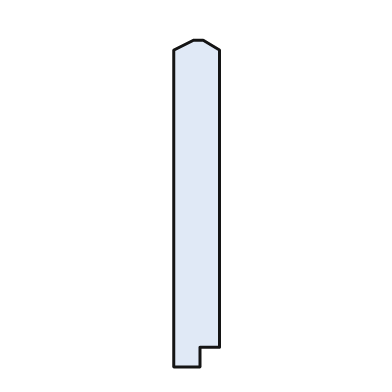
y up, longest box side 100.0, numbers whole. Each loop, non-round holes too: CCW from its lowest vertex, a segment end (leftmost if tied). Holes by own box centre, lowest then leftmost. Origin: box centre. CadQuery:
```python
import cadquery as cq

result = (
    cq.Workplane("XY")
    .moveTo(-7.0, -50.0)
    .lineTo(1.0, -50.0)
    .lineTo(1.0, -44.0)
    .lineTo(7.0, -44.0)
    .lineTo(7.0, 47.0)
    .lineTo(2.0, 50.0)
    .lineTo(-1.0, 50.0)
    .lineTo(-7.0, 47.0)
    .close()
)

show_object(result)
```